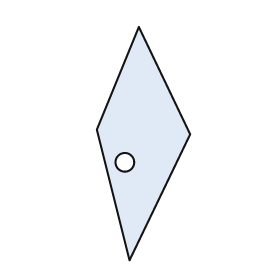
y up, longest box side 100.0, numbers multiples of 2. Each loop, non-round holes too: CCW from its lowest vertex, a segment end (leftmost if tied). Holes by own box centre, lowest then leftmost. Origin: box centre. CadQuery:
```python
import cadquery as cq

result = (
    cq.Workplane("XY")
    .moveTo(-6.0, -50.0)
    .lineTo(20.0, 4.0)
    .lineTo(-2.0, 50.0)
    .lineTo(-20.0, 6.0)
    .close()
    .moveTo(-8.0, -8.0)
    .circle(4.0)
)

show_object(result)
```